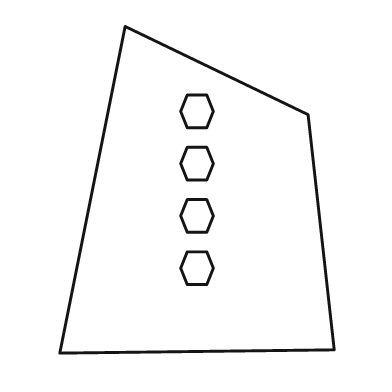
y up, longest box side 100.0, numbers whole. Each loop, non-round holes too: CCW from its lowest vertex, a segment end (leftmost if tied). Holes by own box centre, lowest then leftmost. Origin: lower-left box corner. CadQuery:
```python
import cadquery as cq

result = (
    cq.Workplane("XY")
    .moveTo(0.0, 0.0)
    .lineTo(84.0, 1.0)
    .lineTo(76.0, 73.0)
    .lineTo(20.0, 100.0)
    .close()
    .moveTo(39.0, 21.0)
    .lineTo(45.0, 21.0)
    .lineTo(47.0, 26.0)
    .lineTo(45.0, 31.0)
    .lineTo(39.0, 31.0)
    .lineTo(37.0, 26.0)
    .close()
    .moveTo(39.0, 37.0)
    .lineTo(45.0, 37.0)
    .lineTo(47.0, 42.0)
    .lineTo(45.0, 47.0)
    .lineTo(39.0, 47.0)
    .lineTo(37.0, 42.0)
    .close()
    .moveTo(39.0, 53.0)
    .lineTo(45.0, 53.0)
    .lineTo(47.0, 58.0)
    .lineTo(45.0, 63.0)
    .lineTo(39.0, 63.0)
    .lineTo(37.0, 58.0)
    .close()
    .moveTo(39.0, 69.0)
    .lineTo(45.0, 69.0)
    .lineTo(47.0, 74.0)
    .lineTo(45.0, 79.0)
    .lineTo(39.0, 79.0)
    .lineTo(37.0, 74.0)
    .close()
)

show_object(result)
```